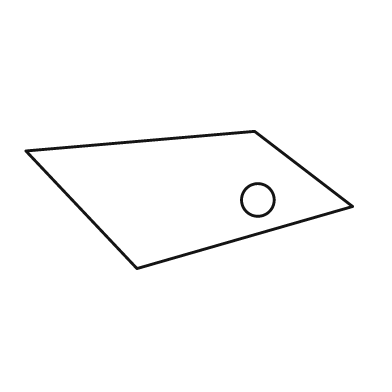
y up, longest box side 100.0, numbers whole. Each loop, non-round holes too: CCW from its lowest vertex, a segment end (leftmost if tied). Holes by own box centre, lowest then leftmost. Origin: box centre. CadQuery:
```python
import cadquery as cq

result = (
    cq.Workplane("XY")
    .moveTo(-16.0, -21.0)
    .lineTo(50.0, -2.0)
    .lineTo(20.0, 21.0)
    .lineTo(-50.0, 15.0)
    .close()
    .moveTo(21.0, 0.0)
    .circle(5.0)
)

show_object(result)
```